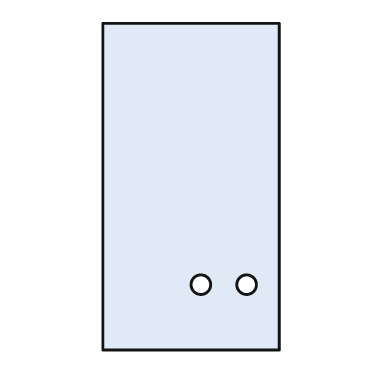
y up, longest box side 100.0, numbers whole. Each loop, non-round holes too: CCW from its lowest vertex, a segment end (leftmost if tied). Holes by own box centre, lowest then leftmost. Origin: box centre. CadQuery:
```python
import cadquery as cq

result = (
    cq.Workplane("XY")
    .moveTo(-27.0, -50.0)
    .lineTo(27.0, -50.0)
    .lineTo(27.0, 50.0)
    .lineTo(-27.0, 50.0)
    .close()
    .moveTo(3.0, -30.0)
    .circle(3.0)
    .moveTo(17.0, -30.0)
    .circle(3.0)
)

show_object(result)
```